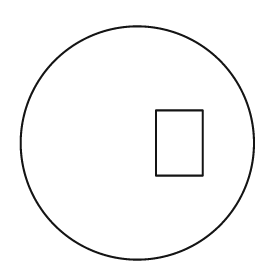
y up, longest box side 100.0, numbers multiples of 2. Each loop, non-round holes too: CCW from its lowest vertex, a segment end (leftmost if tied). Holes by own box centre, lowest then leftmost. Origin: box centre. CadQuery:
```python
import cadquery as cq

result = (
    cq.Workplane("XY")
    .moveTo(0.0, 0.0)
    .circle(50.0)
    .moveTo(8.0, -14.0)
    .lineTo(28.0, -14.0)
    .lineTo(28.0, 14.0)
    .lineTo(8.0, 14.0)
    .close()
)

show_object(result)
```